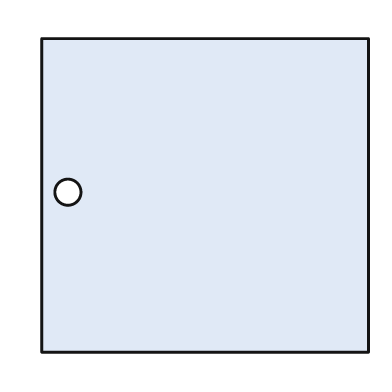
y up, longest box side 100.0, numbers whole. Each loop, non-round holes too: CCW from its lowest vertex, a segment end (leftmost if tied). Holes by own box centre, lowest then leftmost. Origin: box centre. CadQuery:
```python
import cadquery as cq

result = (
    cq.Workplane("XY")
    .moveTo(-50.0, -48.0)
    .lineTo(50.0, -48.0)
    .lineTo(50.0, 48.0)
    .lineTo(-50.0, 48.0)
    .close()
    .moveTo(-42.0, 1.0)
    .circle(4.0)
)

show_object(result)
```